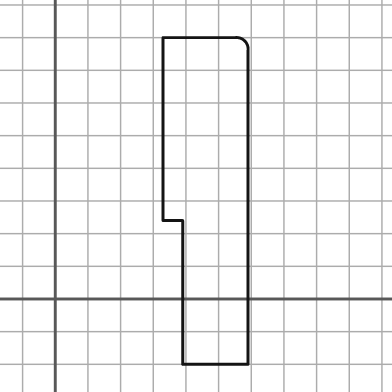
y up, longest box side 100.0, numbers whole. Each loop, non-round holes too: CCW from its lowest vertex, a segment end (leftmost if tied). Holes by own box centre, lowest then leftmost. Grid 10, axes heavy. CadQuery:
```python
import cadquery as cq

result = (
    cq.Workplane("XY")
    .moveTo(39.0, -20.0)
    .lineTo(59.0, -20.0)
    .lineTo(59.0, 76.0)
    .threePointArc((58.0, 79.0), (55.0, 80.0))
    .lineTo(33.0, 80.0)
    .lineTo(33.0, 24.0)
    .lineTo(39.0, 24.0)
    .close()
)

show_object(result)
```